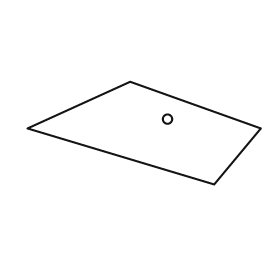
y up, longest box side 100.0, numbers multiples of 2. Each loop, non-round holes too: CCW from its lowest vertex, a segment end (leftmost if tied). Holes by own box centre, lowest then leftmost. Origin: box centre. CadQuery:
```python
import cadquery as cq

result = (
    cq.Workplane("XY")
    .moveTo(30.0, -22.0)
    .lineTo(50.0, 2.0)
    .lineTo(-6.0, 22.0)
    .lineTo(-50.0, 2.0)
    .close()
    .moveTo(10.0, 6.0)
    .circle(2.0)
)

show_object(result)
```